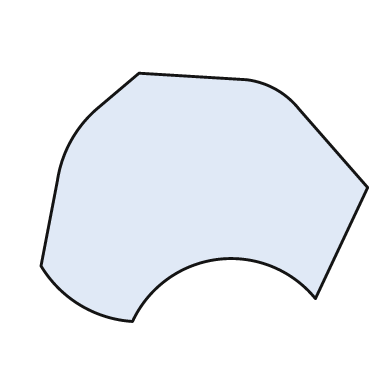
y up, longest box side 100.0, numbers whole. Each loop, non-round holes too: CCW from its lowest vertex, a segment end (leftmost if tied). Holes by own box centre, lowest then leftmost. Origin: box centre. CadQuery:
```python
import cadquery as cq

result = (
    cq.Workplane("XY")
    .moveTo(-22.0, -38.0)
    .threePointArc((4.0, -19.0), (34.0, -31.0))
    .lineTo(50.0, 3.0)
    .lineTo(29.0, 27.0)
    .threePointArc((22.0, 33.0), (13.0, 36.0))
    .lineTo(-20.0, 38.0)
    .lineTo(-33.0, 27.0)
    .threePointArc((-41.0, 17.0), (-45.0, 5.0))
    .lineTo(-50.0, -21.0)
    .threePointArc((-38.0, -33.0), (-22.0, -38.0))
    .close()
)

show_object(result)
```